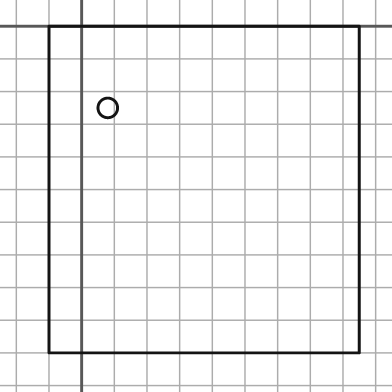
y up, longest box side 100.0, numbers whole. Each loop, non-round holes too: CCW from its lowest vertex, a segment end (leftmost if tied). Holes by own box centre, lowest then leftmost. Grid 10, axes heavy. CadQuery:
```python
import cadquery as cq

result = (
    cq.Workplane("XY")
    .moveTo(-10.0, -100.0)
    .lineTo(85.0, -100.0)
    .lineTo(85.0, 0.0)
    .lineTo(-10.0, 0.0)
    .close()
    .moveTo(8.0, -25.0)
    .circle(3.0)
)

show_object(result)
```